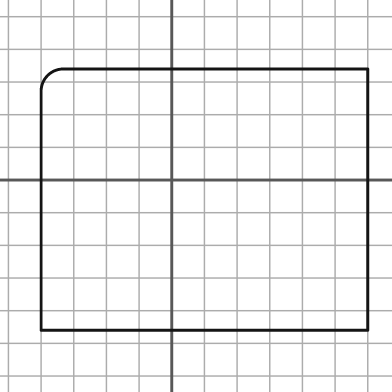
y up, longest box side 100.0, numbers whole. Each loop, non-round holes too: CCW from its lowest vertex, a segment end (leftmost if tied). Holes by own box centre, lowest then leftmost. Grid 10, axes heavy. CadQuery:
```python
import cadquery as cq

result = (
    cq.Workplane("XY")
    .moveTo(-40.0, -46.0)
    .lineTo(60.0, -46.0)
    .lineTo(60.0, 34.0)
    .lineTo(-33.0, 34.0)
    .threePointArc((-38.0, 32.0), (-40.0, 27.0))
    .close()
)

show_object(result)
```